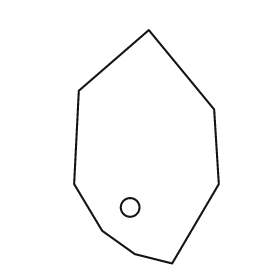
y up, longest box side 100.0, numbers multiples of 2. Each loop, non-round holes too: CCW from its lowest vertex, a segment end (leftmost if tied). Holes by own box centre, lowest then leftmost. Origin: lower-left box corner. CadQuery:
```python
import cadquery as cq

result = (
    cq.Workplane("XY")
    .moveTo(42.0, 0.0)
    .lineTo(62.0, 34.0)
    .lineTo(60.0, 66.0)
    .lineTo(32.0, 100.0)
    .lineTo(2.0, 74.0)
    .lineTo(0.0, 34.0)
    .lineTo(12.0, 14.0)
    .lineTo(26.0, 4.0)
    .close()
    .moveTo(24.0, 24.0)
    .circle(4.0)
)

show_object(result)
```